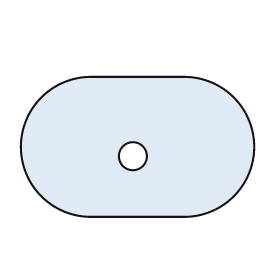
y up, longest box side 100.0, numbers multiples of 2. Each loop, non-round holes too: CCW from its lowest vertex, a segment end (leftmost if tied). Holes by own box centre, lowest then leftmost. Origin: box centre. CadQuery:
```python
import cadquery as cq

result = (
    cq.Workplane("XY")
    .moveTo(-20.0, -30.0)
    .lineTo(20.0, -30.0)
    .threePointArc((50.0, 0.0), (20.0, 30.0))
    .lineTo(-20.0, 30.0)
    .threePointArc((-50.0, 0.0), (-20.0, -30.0))
    .close()
    .moveTo(-2.0, -4.0)
    .circle(6.0)
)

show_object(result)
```